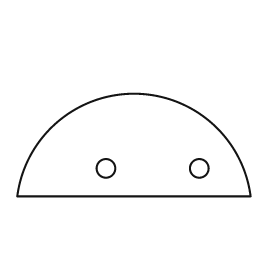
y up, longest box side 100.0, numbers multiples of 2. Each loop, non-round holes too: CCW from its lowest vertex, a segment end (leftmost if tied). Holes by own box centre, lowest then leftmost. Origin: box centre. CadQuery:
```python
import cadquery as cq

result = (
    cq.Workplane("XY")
    .moveTo(-50.0, -22.0)
    .lineTo(50.0, -22.0)
    .threePointArc((0.0, 22.0), (-50.0, -22.0))
    .close()
    .moveTo(-12.0, -10.0)
    .circle(4.0)
    .moveTo(28.0, -10.0)
    .circle(4.0)
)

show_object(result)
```